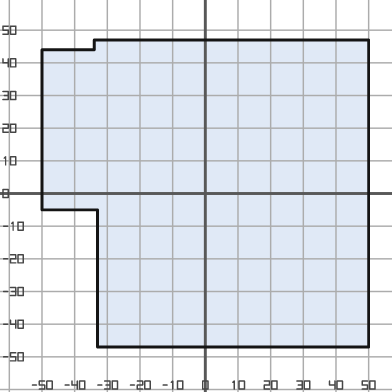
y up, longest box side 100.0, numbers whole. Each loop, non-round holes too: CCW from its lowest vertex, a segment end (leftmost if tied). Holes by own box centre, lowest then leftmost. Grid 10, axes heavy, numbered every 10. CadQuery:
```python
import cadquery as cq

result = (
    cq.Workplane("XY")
    .moveTo(-33.0, -47.0)
    .lineTo(50.0, -47.0)
    .lineTo(50.0, 47.0)
    .lineTo(-34.0, 47.0)
    .lineTo(-34.0, 44.0)
    .lineTo(-50.0, 44.0)
    .lineTo(-50.0, -5.0)
    .lineTo(-33.0, -5.0)
    .close()
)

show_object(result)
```